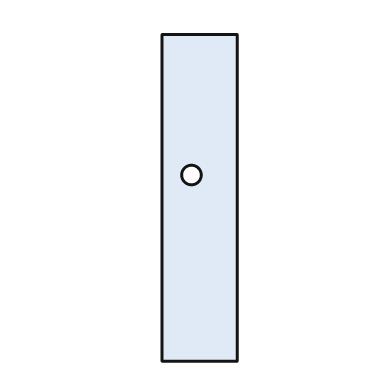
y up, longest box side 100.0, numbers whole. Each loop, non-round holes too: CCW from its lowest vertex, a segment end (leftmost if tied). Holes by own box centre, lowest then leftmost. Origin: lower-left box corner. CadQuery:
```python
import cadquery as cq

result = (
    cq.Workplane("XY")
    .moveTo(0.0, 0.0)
    .lineTo(23.0, 0.0)
    .lineTo(23.0, 100.0)
    .lineTo(0.0, 100.0)
    .close()
    .moveTo(9.0, 57.0)
    .circle(3.0)
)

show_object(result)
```